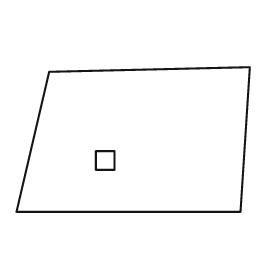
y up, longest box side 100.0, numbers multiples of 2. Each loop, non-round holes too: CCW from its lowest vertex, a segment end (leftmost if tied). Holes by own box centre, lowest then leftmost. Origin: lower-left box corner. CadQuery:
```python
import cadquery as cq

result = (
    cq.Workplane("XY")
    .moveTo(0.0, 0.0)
    .lineTo(96.0, 0.0)
    .lineTo(100.0, 62.0)
    .lineTo(14.0, 60.0)
    .close()
    .moveTo(34.0, 18.0)
    .lineTo(42.0, 18.0)
    .lineTo(42.0, 26.0)
    .lineTo(34.0, 26.0)
    .close()
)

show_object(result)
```